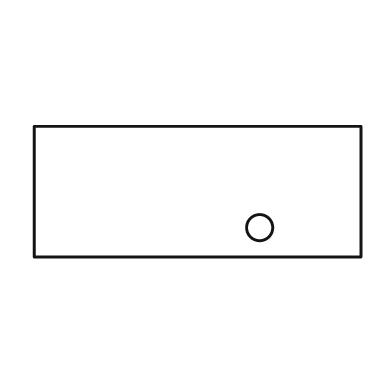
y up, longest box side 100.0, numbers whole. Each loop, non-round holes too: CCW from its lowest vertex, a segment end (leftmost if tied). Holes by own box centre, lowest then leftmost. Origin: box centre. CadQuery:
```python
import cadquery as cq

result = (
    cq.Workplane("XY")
    .moveTo(-50.0, -20.0)
    .lineTo(50.0, -20.0)
    .lineTo(50.0, 20.0)
    .lineTo(-50.0, 20.0)
    .close()
    .moveTo(19.0, -11.0)
    .circle(4.0)
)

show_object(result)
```